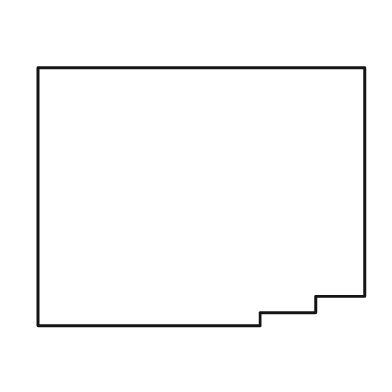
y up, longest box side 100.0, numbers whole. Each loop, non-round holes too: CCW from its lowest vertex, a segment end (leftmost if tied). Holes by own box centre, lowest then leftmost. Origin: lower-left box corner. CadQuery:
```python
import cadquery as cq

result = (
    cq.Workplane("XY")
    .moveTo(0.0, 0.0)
    .lineTo(68.0, 0.0)
    .lineTo(68.0, 4.0)
    .lineTo(85.0, 4.0)
    .lineTo(85.0, 9.0)
    .lineTo(100.0, 9.0)
    .lineTo(100.0, 79.0)
    .lineTo(0.0, 79.0)
    .close()
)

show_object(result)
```